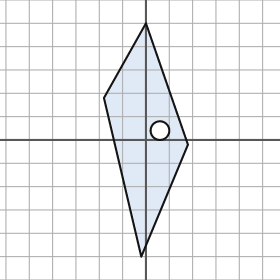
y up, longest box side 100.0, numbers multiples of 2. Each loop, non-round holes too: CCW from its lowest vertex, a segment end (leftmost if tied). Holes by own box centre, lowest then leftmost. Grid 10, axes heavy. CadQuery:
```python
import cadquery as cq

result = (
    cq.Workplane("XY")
    .moveTo(-2.0, -50.0)
    .lineTo(18.0, -2.0)
    .lineTo(0.0, 50.0)
    .lineTo(-18.0, 18.0)
    .close()
    .moveTo(6.0, 4.0)
    .circle(4.0)
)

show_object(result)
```